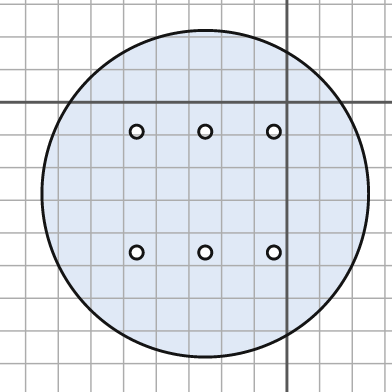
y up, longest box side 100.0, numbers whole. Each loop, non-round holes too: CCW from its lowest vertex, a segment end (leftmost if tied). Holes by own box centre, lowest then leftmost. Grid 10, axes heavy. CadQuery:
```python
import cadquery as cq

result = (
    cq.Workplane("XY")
    .moveTo(-25.0, -28.0)
    .circle(50.0)
    .moveTo(-46.0, -46.0)
    .circle(2.0)
    .moveTo(-25.0, -46.0)
    .circle(2.0)
    .moveTo(-4.0, -46.0)
    .circle(2.0)
    .moveTo(-46.0, -9.0)
    .circle(2.0)
    .moveTo(-25.0, -9.0)
    .circle(2.0)
    .moveTo(-4.0, -9.0)
    .circle(2.0)
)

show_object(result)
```